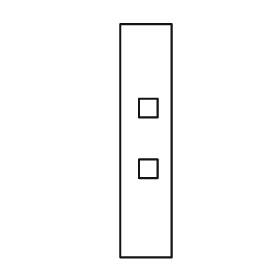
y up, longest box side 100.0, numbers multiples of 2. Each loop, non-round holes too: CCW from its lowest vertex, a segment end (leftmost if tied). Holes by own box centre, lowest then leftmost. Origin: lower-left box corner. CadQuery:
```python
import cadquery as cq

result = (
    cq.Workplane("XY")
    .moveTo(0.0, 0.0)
    .lineTo(22.0, 0.0)
    .lineTo(22.0, 100.0)
    .lineTo(0.0, 100.0)
    .close()
    .moveTo(8.0, 34.0)
    .lineTo(16.0, 34.0)
    .lineTo(16.0, 42.0)
    .lineTo(8.0, 42.0)
    .close()
    .moveTo(8.0, 60.0)
    .lineTo(16.0, 60.0)
    .lineTo(16.0, 68.0)
    .lineTo(8.0, 68.0)
    .close()
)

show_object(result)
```